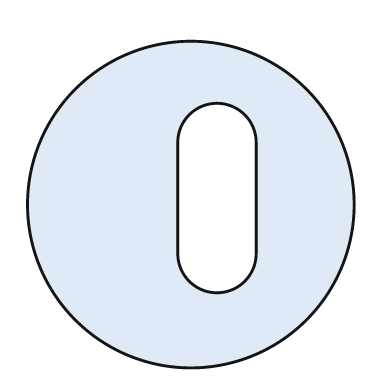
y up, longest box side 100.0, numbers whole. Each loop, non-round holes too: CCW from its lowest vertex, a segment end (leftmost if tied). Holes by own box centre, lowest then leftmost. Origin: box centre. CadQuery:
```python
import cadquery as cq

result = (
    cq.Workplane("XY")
    .moveTo(0.0, 0.0)
    .circle(50.0)
    .moveTo(-4.0, -15.0)
    .threePointArc((8.0, -27.0), (20.0, -15.0))
    .lineTo(20.0, 19.0)
    .threePointArc((8.0, 31.0), (-4.0, 19.0))
    .close()
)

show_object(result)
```